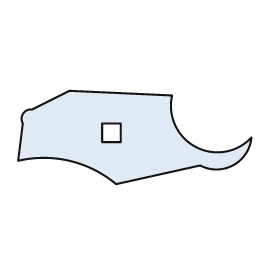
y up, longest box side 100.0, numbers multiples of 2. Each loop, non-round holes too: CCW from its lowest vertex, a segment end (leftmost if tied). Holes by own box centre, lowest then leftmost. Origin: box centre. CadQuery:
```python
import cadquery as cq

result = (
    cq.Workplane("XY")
    .moveTo(-8.0, -20.0)
    .lineTo(28.0, -12.0)
    .threePointArc((42.0, -12.0), (50.0, 0.0))
    .threePointArc((26.0, -4.0), (16.0, 18.0))
    .lineTo(-28.0, 20.0)
    .lineTo(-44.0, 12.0)
    .threePointArc((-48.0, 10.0), (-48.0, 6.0))
    .lineTo(-50.0, -10.0)
    .threePointArc((-28.0, -10.0), (-8.0, -20.0))
    .close()
    .moveTo(-14.0, -2.0)
    .lineTo(-6.0, -2.0)
    .lineTo(-6.0, 6.0)
    .lineTo(-14.0, 6.0)
    .close()
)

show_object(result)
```